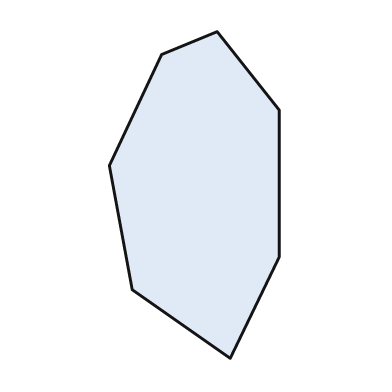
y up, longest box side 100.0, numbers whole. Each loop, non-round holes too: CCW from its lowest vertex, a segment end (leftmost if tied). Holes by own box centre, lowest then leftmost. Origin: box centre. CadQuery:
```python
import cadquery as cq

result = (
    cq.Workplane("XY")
    .moveTo(11.0, -50.0)
    .lineTo(26.0, -19.0)
    .lineTo(26.0, 26.0)
    .lineTo(7.0, 50.0)
    .lineTo(-10.0, 43.0)
    .lineTo(-26.0, 9.0)
    .lineTo(-19.0, -29.0)
    .close()
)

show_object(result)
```